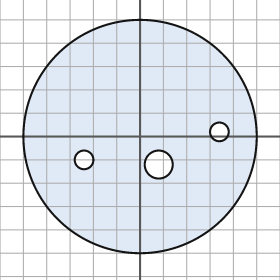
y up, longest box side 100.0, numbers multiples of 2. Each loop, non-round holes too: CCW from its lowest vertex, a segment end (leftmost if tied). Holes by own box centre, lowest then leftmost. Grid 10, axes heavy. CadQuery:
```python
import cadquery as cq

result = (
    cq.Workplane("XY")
    .moveTo(0.0, 0.0)
    .circle(50.0)
    .moveTo(8.0, -12.0)
    .circle(6.0)
    .moveTo(-24.0, -10.0)
    .circle(4.0)
    .moveTo(34.0, 2.0)
    .circle(4.0)
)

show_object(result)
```